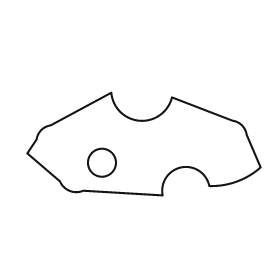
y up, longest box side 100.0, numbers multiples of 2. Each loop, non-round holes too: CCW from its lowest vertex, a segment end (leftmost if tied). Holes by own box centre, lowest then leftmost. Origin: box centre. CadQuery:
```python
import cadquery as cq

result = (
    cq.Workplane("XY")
    .moveTo(8.0, -22.0)
    .threePointArc((16.0, -10.0), (28.0, -18.0))
    .threePointArc((40.0, -16.0), (50.0, -10.0))
    .lineTo(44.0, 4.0)
    .threePointArc((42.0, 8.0), (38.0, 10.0))
    .lineTo(12.0, 20.0)
    .threePointArc((-2.0, 10.0), (-14.0, 22.0))
    .lineTo(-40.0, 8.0)
    .threePointArc((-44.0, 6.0), (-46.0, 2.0))
    .lineTo(-50.0, -4.0)
    .lineTo(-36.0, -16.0)
    .threePointArc((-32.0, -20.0), (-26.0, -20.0))
    .close()
    .moveTo(-18.0, -8.0)
    .circle(6.0)
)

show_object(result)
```